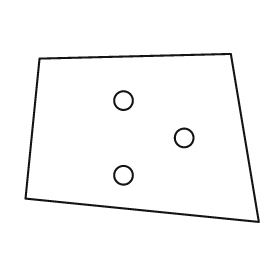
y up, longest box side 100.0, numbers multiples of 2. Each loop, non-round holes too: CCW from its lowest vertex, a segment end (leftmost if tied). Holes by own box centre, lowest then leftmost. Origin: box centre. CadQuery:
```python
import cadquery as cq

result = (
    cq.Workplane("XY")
    .moveTo(50.0, -36.0)
    .lineTo(38.0, 36.0)
    .lineTo(-44.0, 34.0)
    .lineTo(-50.0, -26.0)
    .close()
    .moveTo(-8.0, -16.0)
    .circle(4.0)
    .moveTo(18.0, 0.0)
    .circle(4.0)
    .moveTo(-8.0, 16.0)
    .circle(4.0)
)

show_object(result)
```